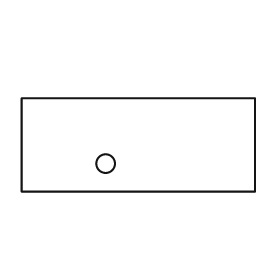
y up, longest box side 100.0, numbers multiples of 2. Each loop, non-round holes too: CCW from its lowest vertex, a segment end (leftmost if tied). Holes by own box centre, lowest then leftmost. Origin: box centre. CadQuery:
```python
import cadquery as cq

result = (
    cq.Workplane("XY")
    .moveTo(-50.0, -20.0)
    .lineTo(50.0, -20.0)
    .lineTo(50.0, 20.0)
    .lineTo(-50.0, 20.0)
    .close()
    .moveTo(-14.0, -8.0)
    .circle(4.0)
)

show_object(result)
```